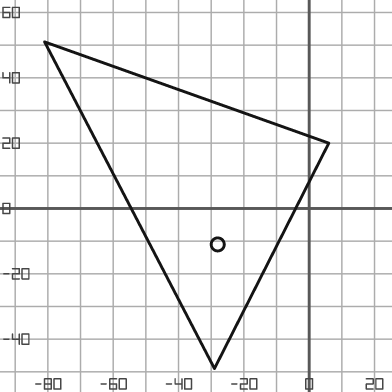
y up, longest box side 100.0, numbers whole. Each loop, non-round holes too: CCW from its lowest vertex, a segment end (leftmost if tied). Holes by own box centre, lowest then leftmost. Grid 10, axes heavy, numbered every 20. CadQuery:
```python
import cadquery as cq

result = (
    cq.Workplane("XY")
    .moveTo(-29.0, -49.0)
    .lineTo(6.0, 20.0)
    .lineTo(-81.0, 51.0)
    .close()
    .moveTo(-28.0, -11.0)
    .circle(2.0)
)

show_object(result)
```